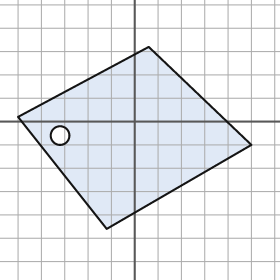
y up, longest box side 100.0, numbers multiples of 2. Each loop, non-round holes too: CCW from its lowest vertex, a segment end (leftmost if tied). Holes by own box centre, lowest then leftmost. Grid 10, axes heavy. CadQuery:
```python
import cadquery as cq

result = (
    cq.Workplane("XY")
    .moveTo(-12.0, -46.0)
    .lineTo(50.0, -10.0)
    .lineTo(6.0, 32.0)
    .lineTo(-50.0, 2.0)
    .close()
    .moveTo(-32.0, -6.0)
    .circle(4.0)
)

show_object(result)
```